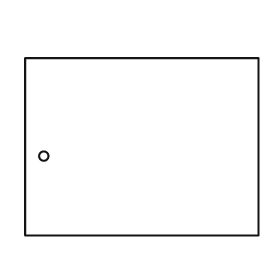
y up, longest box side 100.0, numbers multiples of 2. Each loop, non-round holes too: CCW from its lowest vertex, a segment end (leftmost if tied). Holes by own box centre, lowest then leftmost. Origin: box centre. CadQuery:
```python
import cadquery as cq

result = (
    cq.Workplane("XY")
    .moveTo(-50.0, -38.0)
    .lineTo(50.0, -38.0)
    .lineTo(50.0, 38.0)
    .lineTo(-50.0, 38.0)
    .close()
    .moveTo(-42.0, -4.0)
    .circle(2.0)
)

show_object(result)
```